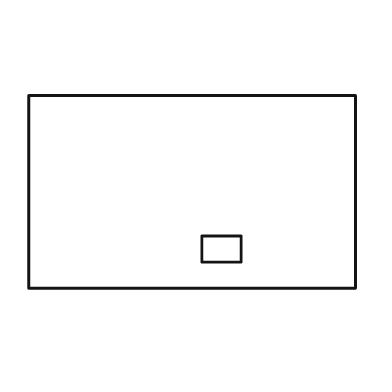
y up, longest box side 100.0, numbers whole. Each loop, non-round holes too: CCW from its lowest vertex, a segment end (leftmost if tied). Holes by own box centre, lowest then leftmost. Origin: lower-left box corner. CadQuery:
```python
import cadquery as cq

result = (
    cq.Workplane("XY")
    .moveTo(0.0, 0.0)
    .lineTo(100.0, 0.0)
    .lineTo(100.0, 59.0)
    .lineTo(0.0, 59.0)
    .close()
    .moveTo(53.0, 8.0)
    .lineTo(65.0, 8.0)
    .lineTo(65.0, 16.0)
    .lineTo(53.0, 16.0)
    .close()
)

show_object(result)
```